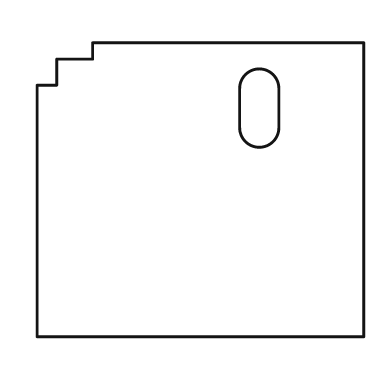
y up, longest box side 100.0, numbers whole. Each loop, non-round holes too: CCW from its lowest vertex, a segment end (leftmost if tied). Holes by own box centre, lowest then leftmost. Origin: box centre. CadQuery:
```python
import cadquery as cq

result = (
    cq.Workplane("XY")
    .moveTo(-50.0, -45.0)
    .lineTo(50.0, -45.0)
    .lineTo(50.0, 45.0)
    .lineTo(-33.0, 45.0)
    .lineTo(-33.0, 40.0)
    .lineTo(-44.0, 40.0)
    .lineTo(-44.0, 32.0)
    .lineTo(-50.0, 32.0)
    .close()
    .moveTo(12.0, 19.0)
    .threePointArc((18.0, 13.0), (24.0, 19.0))
    .lineTo(24.0, 31.0)
    .threePointArc((18.0, 37.0), (12.0, 31.0))
    .close()
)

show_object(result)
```